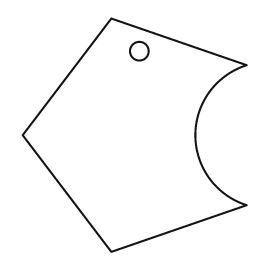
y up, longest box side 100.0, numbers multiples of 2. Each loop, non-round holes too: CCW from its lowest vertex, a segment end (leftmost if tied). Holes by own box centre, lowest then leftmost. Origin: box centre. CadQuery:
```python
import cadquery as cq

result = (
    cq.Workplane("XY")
    .moveTo(-10.0, -50.0)
    .lineTo(48.0, -30.0)
    .threePointArc((26.0, 0.0), (48.0, 30.0))
    .lineTo(-10.0, 50.0)
    .lineTo(-48.0, 0.0)
    .close()
    .moveTo(2.0, 36.0)
    .circle(4.0)
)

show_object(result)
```